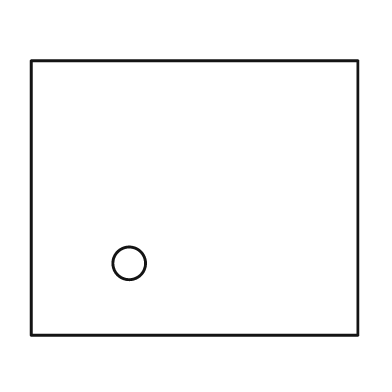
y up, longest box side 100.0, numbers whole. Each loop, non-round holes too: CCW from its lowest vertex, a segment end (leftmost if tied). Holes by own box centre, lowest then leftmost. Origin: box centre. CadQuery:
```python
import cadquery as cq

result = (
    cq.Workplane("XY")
    .moveTo(-50.0, -42.0)
    .lineTo(50.0, -42.0)
    .lineTo(50.0, 42.0)
    .lineTo(-50.0, 42.0)
    .close()
    .moveTo(-20.0, -20.0)
    .circle(5.0)
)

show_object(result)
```